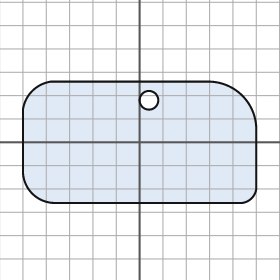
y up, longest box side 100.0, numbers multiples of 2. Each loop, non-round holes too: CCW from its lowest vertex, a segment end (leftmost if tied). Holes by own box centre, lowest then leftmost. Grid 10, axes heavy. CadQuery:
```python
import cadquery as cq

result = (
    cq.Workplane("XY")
    .moveTo(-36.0, -26.0)
    .lineTo(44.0, -26.0)
    .threePointArc((48.0, -24.0), (50.0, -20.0))
    .lineTo(50.0, 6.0)
    .threePointArc((44.0, 20.0), (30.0, 26.0))
    .lineTo(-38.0, 26.0)
    .threePointArc((-46.0, 22.0), (-50.0, 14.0))
    .lineTo(-50.0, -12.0)
    .threePointArc((-46.0, -22.0), (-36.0, -26.0))
    .close()
    .moveTo(4.0, 18.0)
    .circle(4.0)
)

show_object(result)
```